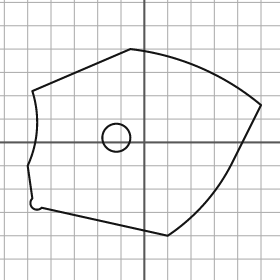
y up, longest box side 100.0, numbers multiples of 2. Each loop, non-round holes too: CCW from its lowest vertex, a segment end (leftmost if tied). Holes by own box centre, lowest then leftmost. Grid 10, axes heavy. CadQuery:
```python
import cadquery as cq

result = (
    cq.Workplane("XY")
    .moveTo(10.0, -40.0)
    .threePointArc((26.0, -26.0), (38.0, -8.0))
    .lineTo(50.0, 16.0)
    .threePointArc((24.0, 32.0), (-6.0, 40.0))
    .lineTo(-48.0, 22.0)
    .threePointArc((-46.0, 6.0), (-50.0, -10.0))
    .lineTo(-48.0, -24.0)
    .threePointArc((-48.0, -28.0), (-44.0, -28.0))
    .close()
    .moveTo(-12.0, 2.0)
    .circle(6.0)
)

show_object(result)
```